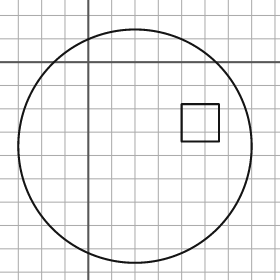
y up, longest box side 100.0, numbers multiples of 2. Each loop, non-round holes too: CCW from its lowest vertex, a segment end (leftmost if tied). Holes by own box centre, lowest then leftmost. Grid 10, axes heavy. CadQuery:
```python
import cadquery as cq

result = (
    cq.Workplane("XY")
    .moveTo(20.0, -36.0)
    .circle(50.0)
    .moveTo(40.0, -34.0)
    .lineTo(56.0, -34.0)
    .lineTo(56.0, -18.0)
    .lineTo(40.0, -18.0)
    .close()
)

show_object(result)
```